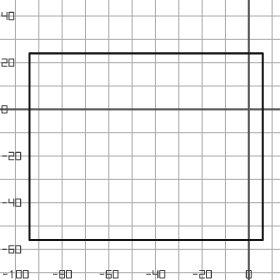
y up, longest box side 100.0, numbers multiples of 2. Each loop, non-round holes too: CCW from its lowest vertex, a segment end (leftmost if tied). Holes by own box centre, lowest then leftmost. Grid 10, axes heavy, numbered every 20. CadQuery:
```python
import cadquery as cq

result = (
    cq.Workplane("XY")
    .moveTo(-94.0, -56.0)
    .lineTo(6.0, -56.0)
    .lineTo(6.0, 24.0)
    .lineTo(-94.0, 24.0)
    .close()
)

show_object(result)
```